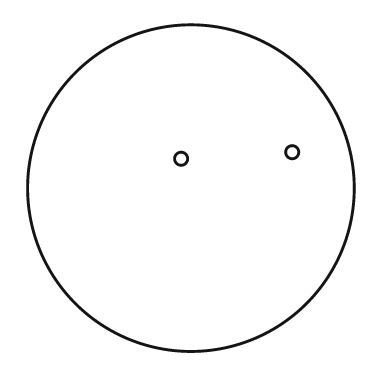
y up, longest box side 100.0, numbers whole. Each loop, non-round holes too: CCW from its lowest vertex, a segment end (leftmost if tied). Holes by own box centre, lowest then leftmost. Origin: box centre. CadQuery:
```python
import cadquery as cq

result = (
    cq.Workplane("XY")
    .moveTo(0.0, 0.0)
    .circle(50.0)
    .moveTo(-3.0, 9.0)
    .circle(2.0)
    .moveTo(31.0, 11.0)
    .circle(2.0)
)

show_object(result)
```